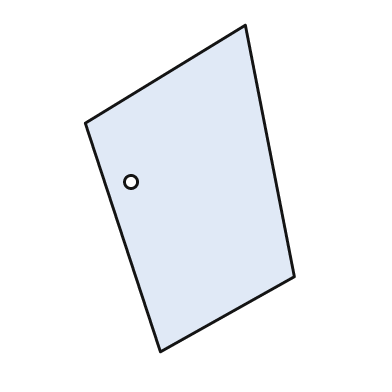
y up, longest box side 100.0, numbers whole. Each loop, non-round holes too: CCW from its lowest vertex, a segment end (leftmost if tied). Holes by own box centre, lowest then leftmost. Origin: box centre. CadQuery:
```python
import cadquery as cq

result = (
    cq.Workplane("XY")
    .moveTo(-9.0, -50.0)
    .lineTo(32.0, -27.0)
    .lineTo(17.0, 50.0)
    .lineTo(-32.0, 20.0)
    .close()
    .moveTo(-18.0, 2.0)
    .circle(2.0)
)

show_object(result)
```